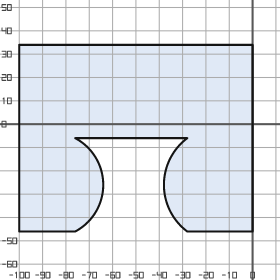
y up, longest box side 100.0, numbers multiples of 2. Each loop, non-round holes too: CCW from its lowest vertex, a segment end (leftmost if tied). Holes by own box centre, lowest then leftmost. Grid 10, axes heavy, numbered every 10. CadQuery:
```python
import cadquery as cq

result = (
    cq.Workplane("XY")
    .moveTo(-100.0, -46.0)
    .lineTo(-76.0, -46.0)
    .threePointArc((-64.0, -26.0), (-76.0, -6.0))
    .lineTo(-28.0, -6.0)
    .threePointArc((-38.0, -26.0), (-28.0, -46.0))
    .lineTo(0.0, -46.0)
    .lineTo(0.0, 34.0)
    .lineTo(-100.0, 34.0)
    .close()
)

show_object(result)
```